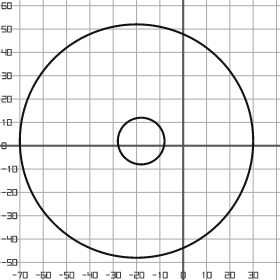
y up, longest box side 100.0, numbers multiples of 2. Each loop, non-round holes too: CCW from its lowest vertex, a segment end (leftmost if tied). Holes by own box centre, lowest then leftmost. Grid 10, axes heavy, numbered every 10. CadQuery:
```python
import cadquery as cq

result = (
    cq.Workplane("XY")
    .moveTo(-20.0, 2.0)
    .circle(50.0)
    .moveTo(-18.0, 2.0)
    .circle(10.0)
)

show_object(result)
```